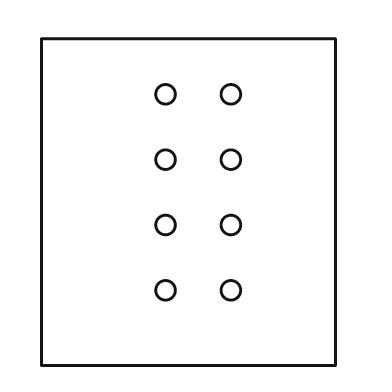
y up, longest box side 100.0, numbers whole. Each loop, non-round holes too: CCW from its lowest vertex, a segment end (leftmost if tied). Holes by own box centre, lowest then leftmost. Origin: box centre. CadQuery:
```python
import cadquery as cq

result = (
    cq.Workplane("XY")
    .moveTo(-45.0, -50.0)
    .lineTo(45.0, -50.0)
    .lineTo(45.0, 50.0)
    .lineTo(-45.0, 50.0)
    .close()
    .moveTo(-7.0, -27.0)
    .circle(3.0)
    .moveTo(13.0, -27.0)
    .circle(3.0)
    .moveTo(-7.0, -7.0)
    .circle(3.0)
    .moveTo(13.0, -7.0)
    .circle(3.0)
    .moveTo(-7.0, 13.0)
    .circle(3.0)
    .moveTo(13.0, 13.0)
    .circle(3.0)
    .moveTo(-7.0, 33.0)
    .circle(3.0)
    .moveTo(13.0, 33.0)
    .circle(3.0)
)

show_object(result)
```